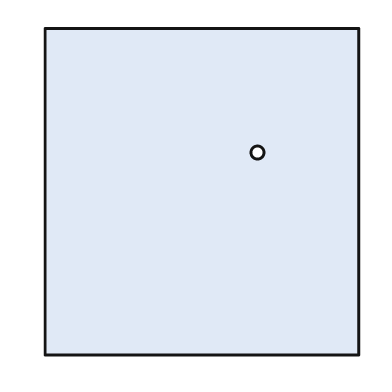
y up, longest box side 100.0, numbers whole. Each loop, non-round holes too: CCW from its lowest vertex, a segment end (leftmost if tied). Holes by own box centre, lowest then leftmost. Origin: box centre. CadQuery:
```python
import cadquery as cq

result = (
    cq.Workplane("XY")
    .moveTo(-48.0, -50.0)
    .lineTo(48.0, -50.0)
    .lineTo(48.0, 50.0)
    .lineTo(-48.0, 50.0)
    .close()
    .moveTo(17.0, 12.0)
    .circle(2.0)
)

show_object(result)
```